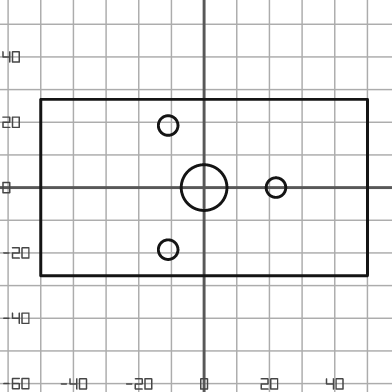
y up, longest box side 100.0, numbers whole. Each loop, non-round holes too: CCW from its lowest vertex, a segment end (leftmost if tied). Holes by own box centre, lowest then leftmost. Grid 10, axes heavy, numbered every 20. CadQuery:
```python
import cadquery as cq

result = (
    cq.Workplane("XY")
    .moveTo(-50.0, -27.0)
    .lineTo(50.0, -27.0)
    .lineTo(50.0, 27.0)
    .lineTo(-50.0, 27.0)
    .close()
    .moveTo(-11.0, -19.0)
    .circle(3.0)
    .moveTo(0.0, 0.0)
    .circle(7.0)
    .moveTo(22.0, 0.0)
    .circle(3.0)
    .moveTo(-11.0, 19.0)
    .circle(3.0)
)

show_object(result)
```